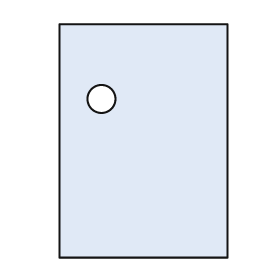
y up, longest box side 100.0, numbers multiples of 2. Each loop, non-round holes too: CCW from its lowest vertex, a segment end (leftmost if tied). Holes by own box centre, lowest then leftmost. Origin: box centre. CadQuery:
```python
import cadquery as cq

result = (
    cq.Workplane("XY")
    .moveTo(-36.0, -50.0)
    .lineTo(36.0, -50.0)
    .lineTo(36.0, 50.0)
    .lineTo(-36.0, 50.0)
    .close()
    .moveTo(-18.0, 18.0)
    .circle(6.0)
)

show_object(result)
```